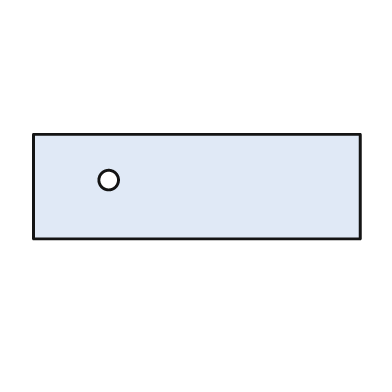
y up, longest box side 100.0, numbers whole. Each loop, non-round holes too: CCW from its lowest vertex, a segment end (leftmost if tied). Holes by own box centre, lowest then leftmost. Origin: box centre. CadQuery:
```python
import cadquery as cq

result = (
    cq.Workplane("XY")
    .moveTo(-50.0, -16.0)
    .lineTo(50.0, -16.0)
    .lineTo(50.0, 16.0)
    .lineTo(-50.0, 16.0)
    .close()
    .moveTo(-27.0, 2.0)
    .circle(3.0)
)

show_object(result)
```